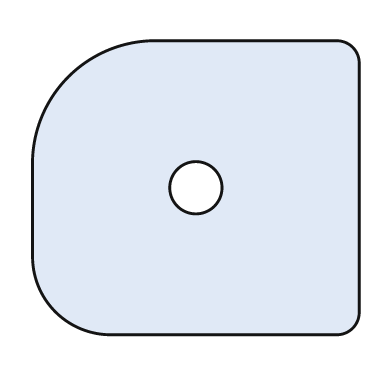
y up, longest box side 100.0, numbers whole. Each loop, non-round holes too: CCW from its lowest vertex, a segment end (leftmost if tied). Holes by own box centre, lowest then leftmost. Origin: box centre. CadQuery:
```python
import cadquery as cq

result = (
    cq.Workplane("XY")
    .moveTo(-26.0, -45.0)
    .lineTo(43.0, -45.0)
    .threePointArc((48.0, -43.0), (50.0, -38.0))
    .lineTo(50.0, 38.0)
    .threePointArc((48.0, 43.0), (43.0, 45.0))
    .lineTo(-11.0, 45.0)
    .threePointArc((-39.0, 34.0), (-50.0, 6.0))
    .lineTo(-50.0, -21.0)
    .threePointArc((-43.0, -38.0), (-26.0, -45.0))
    .close()
    .moveTo(0.0, 0.0)
    .circle(8.0)
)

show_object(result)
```